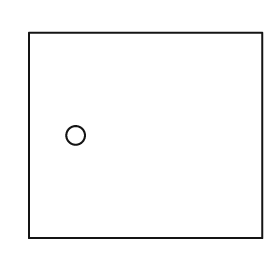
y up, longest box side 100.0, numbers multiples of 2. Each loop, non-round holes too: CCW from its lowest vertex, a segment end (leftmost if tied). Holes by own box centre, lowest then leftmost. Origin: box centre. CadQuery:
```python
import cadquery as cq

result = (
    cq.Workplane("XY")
    .moveTo(-50.0, -44.0)
    .lineTo(50.0, -44.0)
    .lineTo(50.0, 44.0)
    .lineTo(-50.0, 44.0)
    .close()
    .moveTo(-30.0, 0.0)
    .circle(4.0)
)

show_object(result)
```